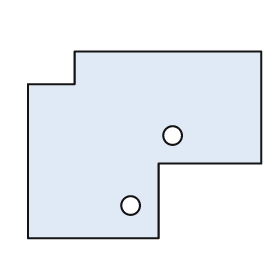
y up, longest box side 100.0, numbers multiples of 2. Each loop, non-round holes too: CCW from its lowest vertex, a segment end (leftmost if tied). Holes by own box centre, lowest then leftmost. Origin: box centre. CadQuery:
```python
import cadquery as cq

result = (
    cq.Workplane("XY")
    .moveTo(-50.0, -40.0)
    .lineTo(6.0, -40.0)
    .lineTo(6.0, -8.0)
    .lineTo(50.0, -8.0)
    .lineTo(50.0, 40.0)
    .lineTo(-30.0, 40.0)
    .lineTo(-30.0, 26.0)
    .lineTo(-50.0, 26.0)
    .close()
    .moveTo(-6.0, -26.0)
    .circle(4.0)
    .moveTo(12.0, 4.0)
    .circle(4.0)
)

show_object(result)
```